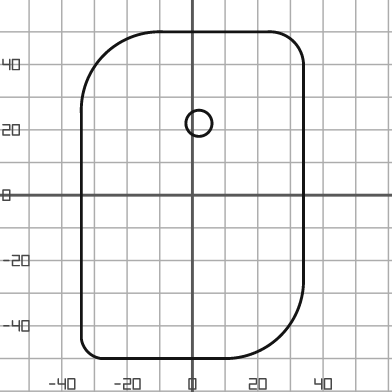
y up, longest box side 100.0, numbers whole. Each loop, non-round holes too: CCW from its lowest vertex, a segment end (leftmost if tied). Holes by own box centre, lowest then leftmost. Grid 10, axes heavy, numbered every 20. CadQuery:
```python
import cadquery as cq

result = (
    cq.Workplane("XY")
    .moveTo(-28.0, -50.0)
    .lineTo(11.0, -50.0)
    .threePointArc((27.0, -43.0), (34.0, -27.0))
    .lineTo(34.0, 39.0)
    .threePointArc((31.0, 47.0), (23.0, 50.0))
    .lineTo(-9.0, 50.0)
    .threePointArc((-27.0, 43.0), (-34.0, 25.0))
    .lineTo(-34.0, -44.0)
    .threePointArc((-32.0, -48.0), (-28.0, -50.0))
    .close()
    .moveTo(2.0, 22.0)
    .circle(4.0)
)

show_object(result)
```